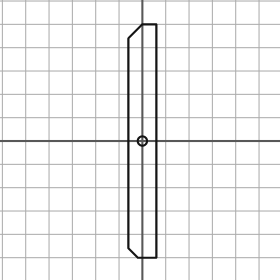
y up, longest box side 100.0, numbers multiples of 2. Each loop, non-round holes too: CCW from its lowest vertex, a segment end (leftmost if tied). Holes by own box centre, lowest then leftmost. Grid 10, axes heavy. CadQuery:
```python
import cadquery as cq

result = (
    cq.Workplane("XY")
    .moveTo(-2.0, -50.0)
    .lineTo(6.0, -50.0)
    .lineTo(6.0, 50.0)
    .lineTo(0.0, 50.0)
    .lineTo(-6.0, 44.0)
    .lineTo(-6.0, -46.0)
    .close()
    .moveTo(0.0, 0.0)
    .circle(2.0)
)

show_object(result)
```